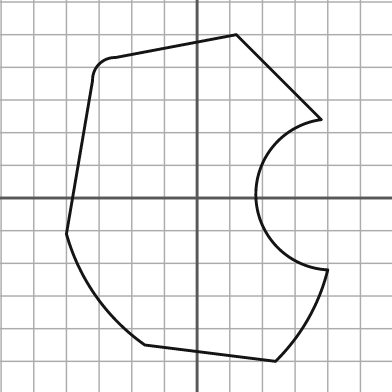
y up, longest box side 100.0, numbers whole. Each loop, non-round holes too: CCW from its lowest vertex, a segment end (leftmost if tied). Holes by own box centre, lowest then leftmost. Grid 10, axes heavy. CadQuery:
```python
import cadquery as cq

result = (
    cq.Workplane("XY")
    .moveTo(24.0, -50.0)
    .threePointArc((34.0, -37.0), (40.0, -22.0))
    .threePointArc((18.0, 0.0), (38.0, 24.0))
    .lineTo(12.0, 50.0)
    .lineTo(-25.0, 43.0)
    .threePointArc((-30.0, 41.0), (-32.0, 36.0))
    .lineTo(-40.0, -11.0)
    .threePointArc((-31.0, -30.0), (-16.0, -45.0))
    .close()
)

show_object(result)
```